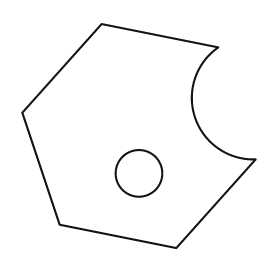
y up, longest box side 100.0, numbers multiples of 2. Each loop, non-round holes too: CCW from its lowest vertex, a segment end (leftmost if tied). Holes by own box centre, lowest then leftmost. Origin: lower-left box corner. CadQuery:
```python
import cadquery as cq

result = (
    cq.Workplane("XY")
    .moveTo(66.0, 0.0)
    .lineTo(100.0, 38.0)
    .threePointArc((74.0, 56.0), (84.0, 86.0))
    .lineTo(34.0, 96.0)
    .lineTo(0.0, 58.0)
    .lineTo(16.0, 10.0)
    .close()
    .moveTo(50.0, 32.0)
    .circle(10.0)
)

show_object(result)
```